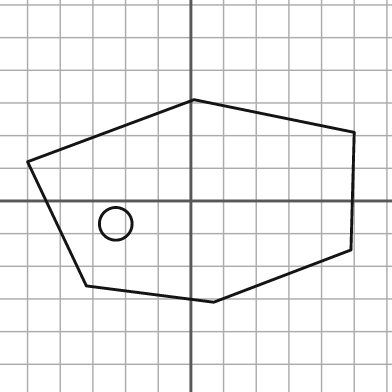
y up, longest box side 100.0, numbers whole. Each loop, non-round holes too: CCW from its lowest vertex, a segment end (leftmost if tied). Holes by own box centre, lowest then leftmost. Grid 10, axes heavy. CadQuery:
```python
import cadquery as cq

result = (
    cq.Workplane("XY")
    .moveTo(7.0, -31.0)
    .lineTo(49.0, -15.0)
    .lineTo(50.0, 21.0)
    .lineTo(1.0, 31.0)
    .lineTo(-50.0, 12.0)
    .lineTo(-32.0, -26.0)
    .close()
    .moveTo(-23.0, -7.0)
    .circle(5.0)
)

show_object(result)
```